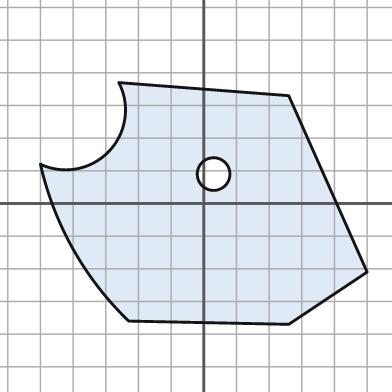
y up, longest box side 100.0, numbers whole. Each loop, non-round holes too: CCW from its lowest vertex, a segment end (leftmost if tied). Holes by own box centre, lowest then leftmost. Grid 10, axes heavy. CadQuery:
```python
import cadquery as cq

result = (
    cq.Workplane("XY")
    .moveTo(26.0, -37.0)
    .lineTo(50.0, -21.0)
    .lineTo(26.0, 33.0)
    .lineTo(-26.0, 37.0)
    .threePointArc((-29.0, 16.0), (-50.0, 12.0))
    .threePointArc((-40.0, -14.0), (-23.0, -36.0))
    .close()
    .moveTo(3.0, 9.0)
    .circle(5.0)
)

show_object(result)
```